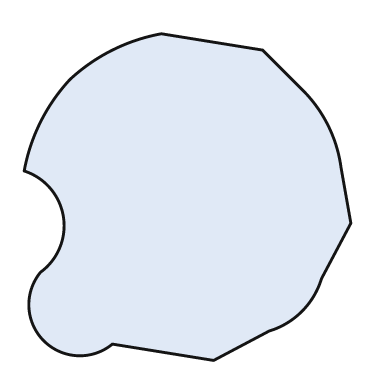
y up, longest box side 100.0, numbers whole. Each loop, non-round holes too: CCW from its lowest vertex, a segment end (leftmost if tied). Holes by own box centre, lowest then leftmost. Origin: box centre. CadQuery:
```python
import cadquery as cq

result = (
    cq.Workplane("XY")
    .moveTo(8.0, -50.0)
    .lineTo(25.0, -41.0)
    .threePointArc((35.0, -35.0), (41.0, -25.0))
    .lineTo(50.0, -8.0)
    .lineTo(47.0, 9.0)
    .threePointArc((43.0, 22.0), (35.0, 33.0))
    .lineTo(23.0, 45.0)
    .lineTo(-8.0, 50.0)
    .threePointArc((-23.0, 45.0), (-36.0, 36.0))
    .threePointArc((-45.0, 23.0), (-50.0, 8.0))
    .threePointArc((-38.0, -6.0), (-45.0, -23.0))
    .threePointArc((-44.0, -44.0), (-23.0, -45.0))
    .close()
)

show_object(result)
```